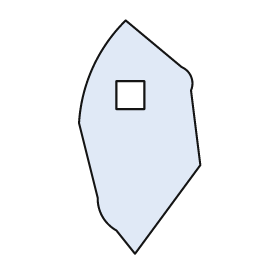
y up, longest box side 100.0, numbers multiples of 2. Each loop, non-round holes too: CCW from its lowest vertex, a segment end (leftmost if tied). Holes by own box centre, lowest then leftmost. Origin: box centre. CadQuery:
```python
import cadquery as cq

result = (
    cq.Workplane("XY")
    .moveTo(-2.0, -50.0)
    .lineTo(26.0, -12.0)
    .lineTo(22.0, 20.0)
    .threePointArc((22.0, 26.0), (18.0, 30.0))
    .lineTo(-6.0, 50.0)
    .threePointArc((-20.0, 30.0), (-26.0, 6.0))
    .lineTo(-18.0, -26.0)
    .threePointArc((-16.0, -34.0), (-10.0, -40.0))
    .close()
    .moveTo(-10.0, 12.0)
    .lineTo(2.0, 12.0)
    .lineTo(2.0, 24.0)
    .lineTo(-10.0, 24.0)
    .close()
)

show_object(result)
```